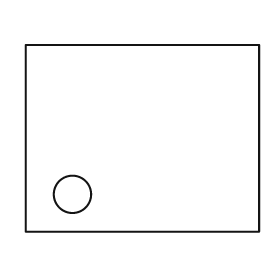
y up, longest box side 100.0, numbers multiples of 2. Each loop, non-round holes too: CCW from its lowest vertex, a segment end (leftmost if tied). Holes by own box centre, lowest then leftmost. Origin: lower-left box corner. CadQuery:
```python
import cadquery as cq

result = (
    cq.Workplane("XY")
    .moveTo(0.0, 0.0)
    .lineTo(100.0, 0.0)
    .lineTo(100.0, 80.0)
    .lineTo(0.0, 80.0)
    .close()
    .moveTo(20.0, 16.0)
    .circle(8.0)
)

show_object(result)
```